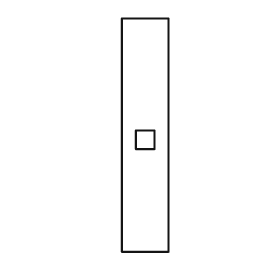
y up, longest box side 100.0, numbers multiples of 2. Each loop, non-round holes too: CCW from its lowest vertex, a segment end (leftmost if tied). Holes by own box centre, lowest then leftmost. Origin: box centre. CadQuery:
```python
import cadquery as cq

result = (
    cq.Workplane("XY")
    .moveTo(-10.0, -50.0)
    .lineTo(10.0, -50.0)
    .lineTo(10.0, 50.0)
    .lineTo(-10.0, 50.0)
    .close()
    .moveTo(-4.0, -6.0)
    .lineTo(4.0, -6.0)
    .lineTo(4.0, 2.0)
    .lineTo(-4.0, 2.0)
    .close()
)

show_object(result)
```